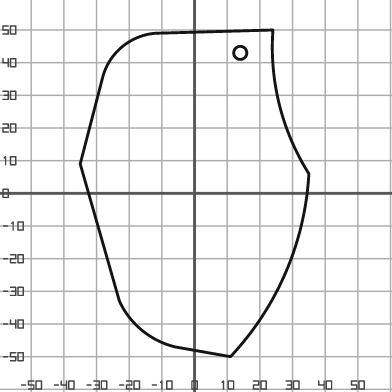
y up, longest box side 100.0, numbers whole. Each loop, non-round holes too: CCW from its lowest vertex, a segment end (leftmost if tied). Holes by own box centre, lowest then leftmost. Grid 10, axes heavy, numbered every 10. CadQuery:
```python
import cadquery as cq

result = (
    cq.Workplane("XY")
    .moveTo(11.0, -50.0)
    .threePointArc((28.0, -24.0), (35.0, 6.0))
    .threePointArc((26.0, 27.0), (24.0, 50.0))
    .lineTo(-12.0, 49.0)
    .threePointArc((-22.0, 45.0), (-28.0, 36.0))
    .lineTo(-35.0, 9.0)
    .lineTo(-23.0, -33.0)
    .threePointArc((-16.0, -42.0), (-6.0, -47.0))
    .close()
    .moveTo(14.0, 43.0)
    .circle(2.0)
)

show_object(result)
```